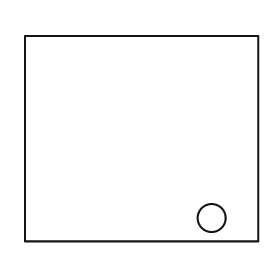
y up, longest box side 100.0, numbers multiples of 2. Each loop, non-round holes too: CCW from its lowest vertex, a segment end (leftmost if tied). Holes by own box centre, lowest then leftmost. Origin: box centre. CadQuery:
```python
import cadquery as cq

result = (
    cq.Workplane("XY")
    .moveTo(-50.0, -44.0)
    .lineTo(50.0, -44.0)
    .lineTo(50.0, 44.0)
    .lineTo(-50.0, 44.0)
    .close()
    .moveTo(30.0, -34.0)
    .circle(6.0)
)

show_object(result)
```